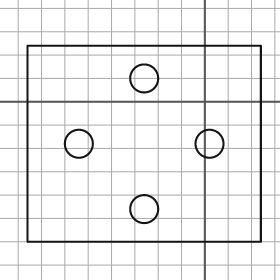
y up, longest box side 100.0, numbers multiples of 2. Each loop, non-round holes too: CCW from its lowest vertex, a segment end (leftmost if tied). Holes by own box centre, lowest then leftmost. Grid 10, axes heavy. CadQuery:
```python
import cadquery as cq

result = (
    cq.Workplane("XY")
    .moveTo(-76.0, -60.0)
    .lineTo(24.0, -60.0)
    .lineTo(24.0, 24.0)
    .lineTo(-76.0, 24.0)
    .close()
    .moveTo(-26.0, -46.0)
    .circle(6.0)
    .moveTo(-54.0, -18.0)
    .circle(6.0)
    .moveTo(2.0, -18.0)
    .circle(6.0)
    .moveTo(-26.0, 10.0)
    .circle(6.0)
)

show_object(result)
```